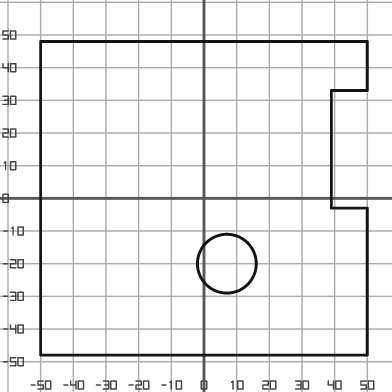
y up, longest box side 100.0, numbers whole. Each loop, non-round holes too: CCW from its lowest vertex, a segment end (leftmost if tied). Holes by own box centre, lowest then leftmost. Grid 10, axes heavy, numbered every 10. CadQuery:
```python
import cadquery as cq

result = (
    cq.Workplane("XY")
    .moveTo(-50.0, -48.0)
    .lineTo(50.0, -48.0)
    .lineTo(50.0, -3.0)
    .lineTo(39.0, -3.0)
    .lineTo(39.0, 33.0)
    .lineTo(50.0, 33.0)
    .lineTo(50.0, 48.0)
    .lineTo(-50.0, 48.0)
    .close()
    .moveTo(7.0, -20.0)
    .circle(9.0)
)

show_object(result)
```